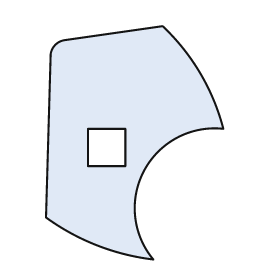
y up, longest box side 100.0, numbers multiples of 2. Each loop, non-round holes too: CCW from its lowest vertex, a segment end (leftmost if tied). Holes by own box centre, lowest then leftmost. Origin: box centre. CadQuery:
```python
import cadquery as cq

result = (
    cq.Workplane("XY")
    .moveTo(8.0, -50.0)
    .threePointArc((4.0, -12.0), (38.0, 6.0))
    .threePointArc((28.0, 30.0), (12.0, 50.0))
    .lineTo(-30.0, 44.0)
    .threePointArc((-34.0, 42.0), (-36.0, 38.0))
    .lineTo(-38.0, -32.0)
    .threePointArc((-16.0, -44.0), (8.0, -50.0))
    .close()
    .moveTo(-20.0, -10.0)
    .lineTo(-4.0, -10.0)
    .lineTo(-4.0, 6.0)
    .lineTo(-20.0, 6.0)
    .close()
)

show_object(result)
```